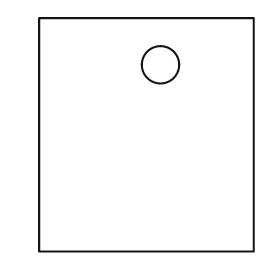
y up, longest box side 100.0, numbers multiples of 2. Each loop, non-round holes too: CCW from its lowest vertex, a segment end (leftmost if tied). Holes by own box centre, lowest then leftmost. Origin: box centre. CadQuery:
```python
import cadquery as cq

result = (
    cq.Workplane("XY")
    .moveTo(-46.0, -50.0)
    .lineTo(46.0, -50.0)
    .lineTo(46.0, 50.0)
    .lineTo(-46.0, 50.0)
    .close()
    .moveTo(6.0, 30.0)
    .circle(8.0)
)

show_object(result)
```